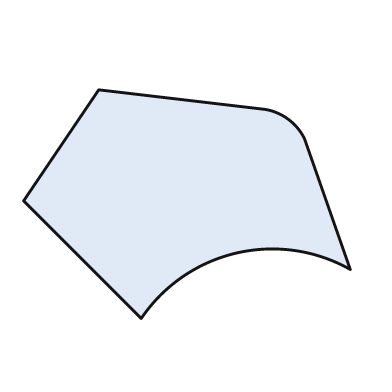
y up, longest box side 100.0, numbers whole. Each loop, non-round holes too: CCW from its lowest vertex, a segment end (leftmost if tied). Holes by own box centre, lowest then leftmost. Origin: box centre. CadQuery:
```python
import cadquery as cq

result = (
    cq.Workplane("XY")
    .moveTo(-14.0, -35.0)
    .threePointArc((15.0, -15.0), (50.0, -20.0))
    .lineTo(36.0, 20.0)
    .threePointArc((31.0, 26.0), (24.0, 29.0))
    .lineTo(-27.0, 35.0)
    .lineTo(-50.0, 1.0)
    .close()
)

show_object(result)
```